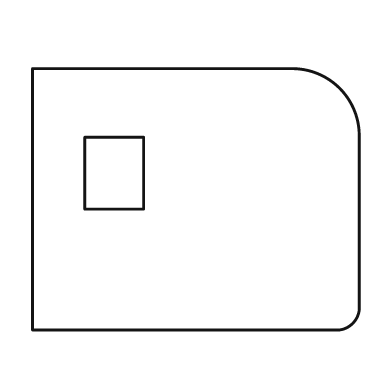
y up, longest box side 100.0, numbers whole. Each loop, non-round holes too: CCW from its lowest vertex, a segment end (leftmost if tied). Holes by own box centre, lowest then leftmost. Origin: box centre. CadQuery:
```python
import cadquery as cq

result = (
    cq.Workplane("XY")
    .moveTo(-50.0, -40.0)
    .lineTo(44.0, -40.0)
    .threePointArc((48.0, -38.0), (50.0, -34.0))
    .lineTo(50.0, 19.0)
    .threePointArc((44.0, 34.0), (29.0, 40.0))
    .lineTo(-50.0, 40.0)
    .close()
    .moveTo(-34.0, -3.0)
    .lineTo(-16.0, -3.0)
    .lineTo(-16.0, 19.0)
    .lineTo(-34.0, 19.0)
    .close()
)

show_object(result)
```